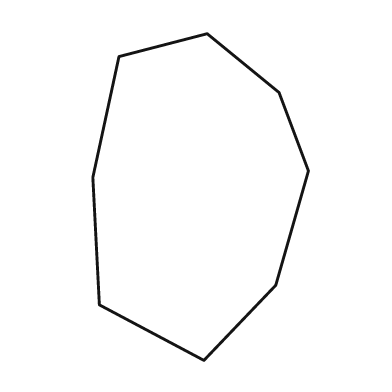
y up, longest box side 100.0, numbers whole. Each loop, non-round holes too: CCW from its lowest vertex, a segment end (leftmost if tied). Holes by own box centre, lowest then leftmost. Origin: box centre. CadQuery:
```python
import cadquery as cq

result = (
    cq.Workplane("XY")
    .moveTo(1.0, -50.0)
    .lineTo(23.0, -27.0)
    .lineTo(33.0, 8.0)
    .lineTo(24.0, 32.0)
    .lineTo(2.0, 50.0)
    .lineTo(-25.0, 43.0)
    .lineTo(-33.0, 6.0)
    .lineTo(-31.0, -33.0)
    .close()
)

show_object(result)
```